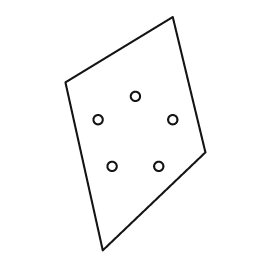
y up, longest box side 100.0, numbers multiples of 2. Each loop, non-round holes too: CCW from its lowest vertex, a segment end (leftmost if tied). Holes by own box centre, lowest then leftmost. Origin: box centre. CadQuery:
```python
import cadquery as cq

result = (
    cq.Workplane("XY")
    .moveTo(-14.0, -50.0)
    .lineTo(30.0, -8.0)
    .lineTo(16.0, 50.0)
    .lineTo(-30.0, 22.0)
    .close()
    .moveTo(-10.0, -14.0)
    .circle(2.0)
    .moveTo(10.0, -14.0)
    .circle(2.0)
    .moveTo(-16.0, 6.0)
    .circle(2.0)
    .moveTo(16.0, 6.0)
    .circle(2.0)
    .moveTo(0.0, 16.0)
    .circle(2.0)
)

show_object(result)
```